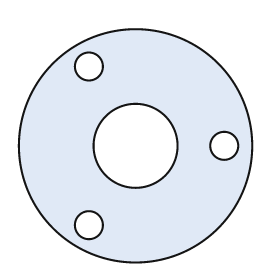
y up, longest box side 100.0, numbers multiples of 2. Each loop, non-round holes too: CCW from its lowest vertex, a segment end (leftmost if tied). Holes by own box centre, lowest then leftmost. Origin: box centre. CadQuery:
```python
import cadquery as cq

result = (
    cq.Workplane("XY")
    .moveTo(0.0, 0.0)
    .circle(50.0)
    .moveTo(-20.0, -34.0)
    .circle(6.0)
    .moveTo(0.0, 0.0)
    .circle(18.0)
    .moveTo(38.0, 0.0)
    .circle(6.0)
    .moveTo(-20.0, 34.0)
    .circle(6.0)
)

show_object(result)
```